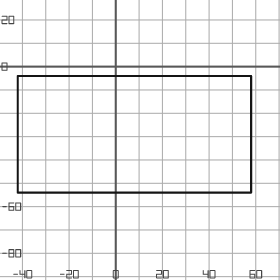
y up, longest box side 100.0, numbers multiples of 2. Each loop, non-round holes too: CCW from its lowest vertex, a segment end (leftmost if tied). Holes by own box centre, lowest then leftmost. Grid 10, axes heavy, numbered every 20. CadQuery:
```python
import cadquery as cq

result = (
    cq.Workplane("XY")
    .moveTo(-42.0, -54.0)
    .lineTo(58.0, -54.0)
    .lineTo(58.0, -4.0)
    .lineTo(-42.0, -4.0)
    .close()
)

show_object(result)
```